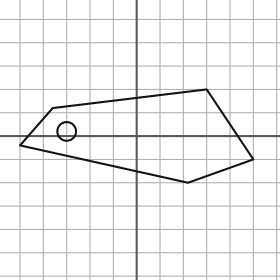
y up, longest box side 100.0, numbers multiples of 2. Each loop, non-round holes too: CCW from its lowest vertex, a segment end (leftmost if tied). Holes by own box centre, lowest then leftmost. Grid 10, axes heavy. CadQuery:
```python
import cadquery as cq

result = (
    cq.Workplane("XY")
    .moveTo(22.0, -20.0)
    .lineTo(50.0, -10.0)
    .lineTo(30.0, 20.0)
    .lineTo(-36.0, 12.0)
    .lineTo(-50.0, -4.0)
    .close()
    .moveTo(-30.0, 2.0)
    .circle(4.0)
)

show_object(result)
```